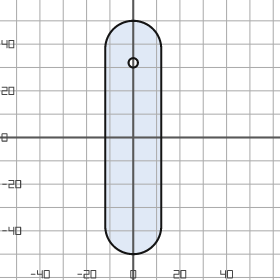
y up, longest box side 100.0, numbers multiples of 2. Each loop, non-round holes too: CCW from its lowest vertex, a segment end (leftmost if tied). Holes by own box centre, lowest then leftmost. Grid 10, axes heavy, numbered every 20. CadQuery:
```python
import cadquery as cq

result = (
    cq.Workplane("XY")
    .moveTo(-12.0, -38.0)
    .threePointArc((0.0, -50.0), (12.0, -38.0))
    .lineTo(12.0, 38.0)
    .threePointArc((0.0, 50.0), (-12.0, 38.0))
    .close()
    .moveTo(0.0, 32.0)
    .circle(2.0)
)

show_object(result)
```